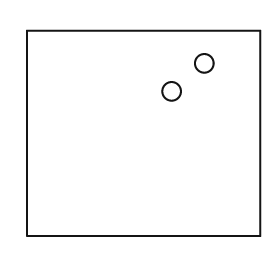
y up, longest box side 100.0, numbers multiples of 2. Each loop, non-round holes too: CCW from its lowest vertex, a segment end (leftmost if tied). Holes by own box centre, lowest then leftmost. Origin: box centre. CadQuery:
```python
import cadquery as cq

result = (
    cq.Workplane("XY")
    .moveTo(-50.0, -44.0)
    .lineTo(50.0, -44.0)
    .lineTo(50.0, 44.0)
    .lineTo(-50.0, 44.0)
    .close()
    .moveTo(12.0, 18.0)
    .circle(4.0)
    .moveTo(26.0, 30.0)
    .circle(4.0)
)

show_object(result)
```